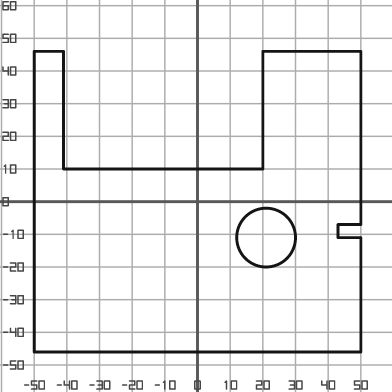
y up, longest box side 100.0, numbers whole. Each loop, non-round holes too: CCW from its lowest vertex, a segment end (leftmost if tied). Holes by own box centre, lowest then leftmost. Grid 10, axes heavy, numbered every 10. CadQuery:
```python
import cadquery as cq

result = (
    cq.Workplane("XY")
    .moveTo(-50.0, -46.0)
    .lineTo(50.0, -46.0)
    .lineTo(50.0, -11.0)
    .lineTo(43.0, -11.0)
    .lineTo(43.0, -7.0)
    .lineTo(50.0, -7.0)
    .lineTo(50.0, 46.0)
    .lineTo(20.0, 46.0)
    .lineTo(20.0, 10.0)
    .lineTo(-41.0, 10.0)
    .lineTo(-41.0, 46.0)
    .lineTo(-50.0, 46.0)
    .close()
    .moveTo(21.0, -11.0)
    .circle(9.0)
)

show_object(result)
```